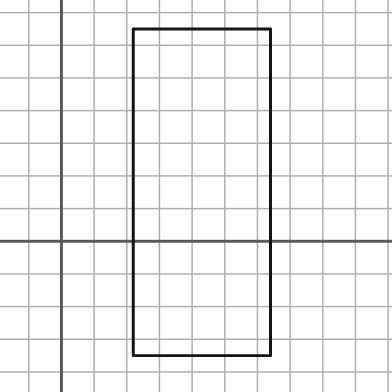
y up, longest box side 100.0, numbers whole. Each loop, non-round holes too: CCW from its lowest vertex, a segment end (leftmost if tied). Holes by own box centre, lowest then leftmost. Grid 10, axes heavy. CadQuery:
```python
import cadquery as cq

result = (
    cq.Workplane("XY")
    .moveTo(22.0, -35.0)
    .lineTo(64.0, -35.0)
    .lineTo(64.0, 65.0)
    .lineTo(22.0, 65.0)
    .close()
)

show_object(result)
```